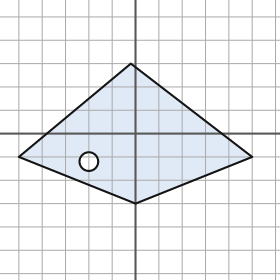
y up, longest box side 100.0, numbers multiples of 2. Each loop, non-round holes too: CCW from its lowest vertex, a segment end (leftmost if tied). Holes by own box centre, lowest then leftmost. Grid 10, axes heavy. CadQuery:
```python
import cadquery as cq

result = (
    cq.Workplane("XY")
    .moveTo(0.0, -30.0)
    .lineTo(50.0, -10.0)
    .lineTo(-2.0, 30.0)
    .lineTo(-50.0, -10.0)
    .close()
    .moveTo(-20.0, -12.0)
    .circle(4.0)
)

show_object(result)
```